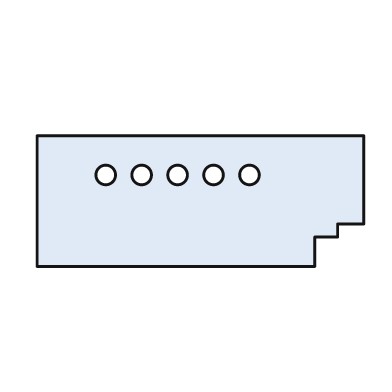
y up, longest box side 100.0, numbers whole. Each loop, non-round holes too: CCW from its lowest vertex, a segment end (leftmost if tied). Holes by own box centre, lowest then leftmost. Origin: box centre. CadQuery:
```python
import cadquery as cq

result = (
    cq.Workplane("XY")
    .moveTo(-50.0, -20.0)
    .lineTo(35.0, -20.0)
    .lineTo(35.0, -11.0)
    .lineTo(42.0, -11.0)
    .lineTo(42.0, -7.0)
    .lineTo(50.0, -7.0)
    .lineTo(50.0, 20.0)
    .lineTo(-50.0, 20.0)
    .close()
    .moveTo(-29.0, 8.0)
    .circle(3.0)
    .moveTo(-18.0, 8.0)
    .circle(3.0)
    .moveTo(-7.0, 8.0)
    .circle(3.0)
    .moveTo(4.0, 8.0)
    .circle(3.0)
    .moveTo(15.0, 8.0)
    .circle(3.0)
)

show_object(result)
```